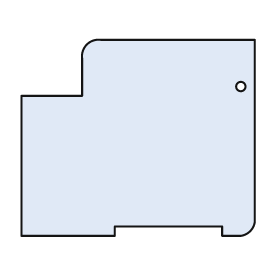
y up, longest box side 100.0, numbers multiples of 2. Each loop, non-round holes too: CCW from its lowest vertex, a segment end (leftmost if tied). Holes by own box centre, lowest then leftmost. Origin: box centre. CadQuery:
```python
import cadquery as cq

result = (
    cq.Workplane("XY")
    .moveTo(-50.0, -42.0)
    .lineTo(-10.0, -42.0)
    .lineTo(-10.0, -38.0)
    .lineTo(36.0, -38.0)
    .lineTo(36.0, -42.0)
    .lineTo(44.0, -42.0)
    .threePointArc((48.0, -40.0), (50.0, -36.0))
    .lineTo(50.0, 42.0)
    .lineTo(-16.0, 42.0)
    .threePointArc((-22.0, 40.0), (-24.0, 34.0))
    .lineTo(-24.0, 18.0)
    .lineTo(-50.0, 18.0)
    .close()
    .moveTo(44.0, 22.0)
    .circle(2.0)
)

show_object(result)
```